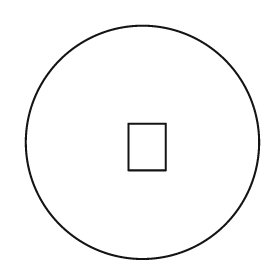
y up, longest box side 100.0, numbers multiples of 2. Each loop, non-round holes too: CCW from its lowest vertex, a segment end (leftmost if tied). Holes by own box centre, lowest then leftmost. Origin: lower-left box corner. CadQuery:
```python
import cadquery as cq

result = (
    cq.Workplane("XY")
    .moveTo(50.0, 50.0)
    .circle(50.0)
    .moveTo(44.0, 38.0)
    .lineTo(60.0, 38.0)
    .lineTo(60.0, 58.0)
    .lineTo(44.0, 58.0)
    .close()
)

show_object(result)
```